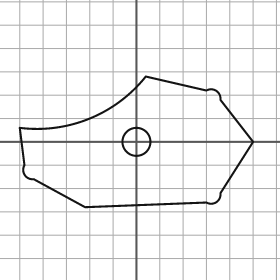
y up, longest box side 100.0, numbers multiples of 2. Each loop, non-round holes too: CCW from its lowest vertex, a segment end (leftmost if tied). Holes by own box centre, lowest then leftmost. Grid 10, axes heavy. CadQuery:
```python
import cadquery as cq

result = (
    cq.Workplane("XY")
    .moveTo(-22.0, -28.0)
    .lineTo(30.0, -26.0)
    .threePointArc((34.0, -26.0), (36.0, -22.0))
    .lineTo(50.0, 0.0)
    .lineTo(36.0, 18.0)
    .threePointArc((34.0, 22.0), (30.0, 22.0))
    .lineTo(4.0, 28.0)
    .threePointArc((-20.0, 10.0), (-50.0, 6.0))
    .lineTo(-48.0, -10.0)
    .threePointArc((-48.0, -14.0), (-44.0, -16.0))
    .close()
    .moveTo(0.0, 0.0)
    .circle(6.0)
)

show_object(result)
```